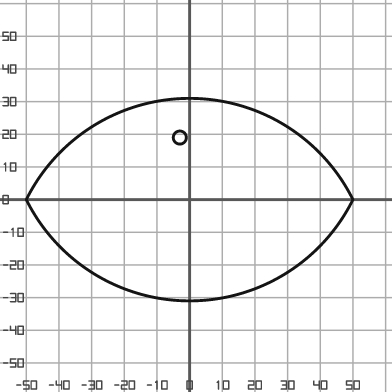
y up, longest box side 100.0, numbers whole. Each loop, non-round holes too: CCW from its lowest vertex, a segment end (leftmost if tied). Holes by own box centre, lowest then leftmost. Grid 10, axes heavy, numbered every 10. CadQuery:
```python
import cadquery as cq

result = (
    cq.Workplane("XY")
    .moveTo(-50.0, 0.0)
    .threePointArc((0.0, -31.0), (50.0, 0.0))
    .threePointArc((0.0, 31.0), (-50.0, 0.0))
    .close()
    .moveTo(-3.0, 19.0)
    .circle(2.0)
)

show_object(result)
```